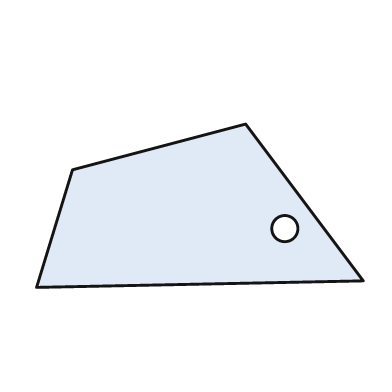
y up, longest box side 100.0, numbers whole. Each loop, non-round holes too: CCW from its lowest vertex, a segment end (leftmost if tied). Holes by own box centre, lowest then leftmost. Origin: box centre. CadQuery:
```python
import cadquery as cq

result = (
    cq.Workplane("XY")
    .moveTo(-50.0, -25.0)
    .lineTo(50.0, -23.0)
    .lineTo(14.0, 25.0)
    .lineTo(-39.0, 11.0)
    .close()
    .moveTo(26.0, -7.0)
    .circle(4.0)
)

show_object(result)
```